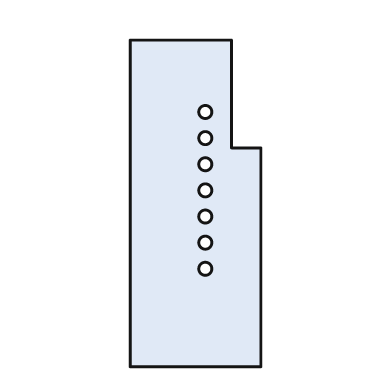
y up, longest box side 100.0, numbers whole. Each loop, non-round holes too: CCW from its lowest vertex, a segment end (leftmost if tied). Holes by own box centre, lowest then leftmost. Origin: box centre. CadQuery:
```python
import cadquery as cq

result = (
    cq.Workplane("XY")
    .moveTo(-20.0, -50.0)
    .lineTo(20.0, -50.0)
    .lineTo(20.0, 17.0)
    .lineTo(11.0, 17.0)
    .lineTo(11.0, 50.0)
    .lineTo(-20.0, 50.0)
    .close()
    .moveTo(3.0, -20.0)
    .circle(2.0)
    .moveTo(3.0, -12.0)
    .circle(2.0)
    .moveTo(3.0, -4.0)
    .circle(2.0)
    .moveTo(3.0, 4.0)
    .circle(2.0)
    .moveTo(3.0, 12.0)
    .circle(2.0)
    .moveTo(3.0, 20.0)
    .circle(2.0)
    .moveTo(3.0, 28.0)
    .circle(2.0)
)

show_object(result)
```